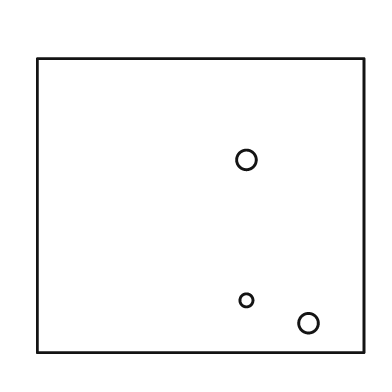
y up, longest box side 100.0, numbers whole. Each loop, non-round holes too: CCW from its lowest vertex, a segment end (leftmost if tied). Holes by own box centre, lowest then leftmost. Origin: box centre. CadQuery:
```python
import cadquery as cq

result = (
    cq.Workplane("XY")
    .moveTo(-50.0, -45.0)
    .lineTo(50.0, -45.0)
    .lineTo(50.0, 45.0)
    .lineTo(-50.0, 45.0)
    .close()
    .moveTo(33.0, -36.0)
    .circle(3.0)
    .moveTo(14.0, -29.0)
    .circle(2.0)
    .moveTo(14.0, 14.0)
    .circle(3.0)
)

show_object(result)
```